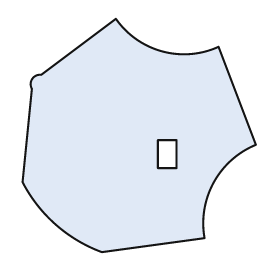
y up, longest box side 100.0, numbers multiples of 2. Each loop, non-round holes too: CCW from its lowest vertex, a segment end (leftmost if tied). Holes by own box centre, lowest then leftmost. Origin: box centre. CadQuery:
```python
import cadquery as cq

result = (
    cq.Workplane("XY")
    .moveTo(-16.0, -50.0)
    .lineTo(28.0, -44.0)
    .threePointArc((32.0, -20.0), (50.0, -4.0))
    .lineTo(34.0, 38.0)
    .threePointArc((10.0, 36.0), (-10.0, 50.0))
    .lineTo(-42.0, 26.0)
    .threePointArc((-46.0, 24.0), (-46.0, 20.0))
    .lineTo(-50.0, -20.0)
    .threePointArc((-36.0, -38.0), (-16.0, -50.0))
    .close()
    .moveTo(8.0, -14.0)
    .lineTo(16.0, -14.0)
    .lineTo(16.0, -2.0)
    .lineTo(8.0, -2.0)
    .close()
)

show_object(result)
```